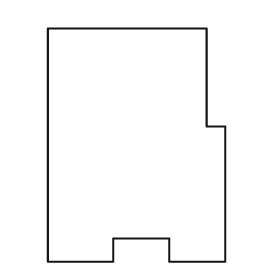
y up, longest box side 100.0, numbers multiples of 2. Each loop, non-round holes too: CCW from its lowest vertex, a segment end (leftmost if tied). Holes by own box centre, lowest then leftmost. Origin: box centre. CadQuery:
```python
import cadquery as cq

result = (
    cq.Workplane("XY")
    .moveTo(-38.0, -50.0)
    .lineTo(-10.0, -50.0)
    .lineTo(-10.0, -40.0)
    .lineTo(14.0, -40.0)
    .lineTo(14.0, -50.0)
    .lineTo(38.0, -50.0)
    .lineTo(38.0, 8.0)
    .lineTo(30.0, 8.0)
    .lineTo(30.0, 50.0)
    .lineTo(-38.0, 50.0)
    .close()
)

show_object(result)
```